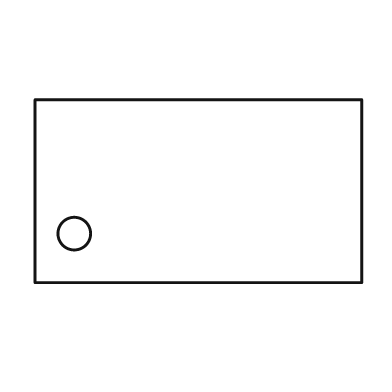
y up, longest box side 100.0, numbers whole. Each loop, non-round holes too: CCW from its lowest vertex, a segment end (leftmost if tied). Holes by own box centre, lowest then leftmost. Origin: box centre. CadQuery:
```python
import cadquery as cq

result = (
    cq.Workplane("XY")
    .moveTo(-50.0, -28.0)
    .lineTo(50.0, -28.0)
    .lineTo(50.0, 28.0)
    .lineTo(-50.0, 28.0)
    .close()
    .moveTo(-38.0, -13.0)
    .circle(5.0)
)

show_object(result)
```